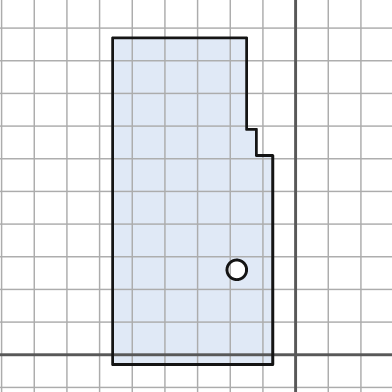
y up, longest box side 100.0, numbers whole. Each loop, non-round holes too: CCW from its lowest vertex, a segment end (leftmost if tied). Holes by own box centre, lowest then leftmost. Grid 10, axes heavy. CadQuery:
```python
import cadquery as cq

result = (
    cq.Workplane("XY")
    .moveTo(-56.0, -3.0)
    .lineTo(-7.0, -3.0)
    .lineTo(-7.0, 61.0)
    .lineTo(-12.0, 61.0)
    .lineTo(-12.0, 69.0)
    .lineTo(-15.0, 69.0)
    .lineTo(-15.0, 97.0)
    .lineTo(-56.0, 97.0)
    .close()
    .moveTo(-18.0, 26.0)
    .circle(3.0)
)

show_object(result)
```